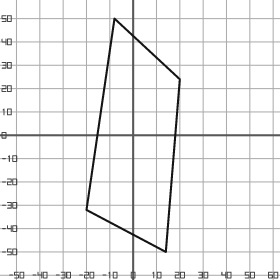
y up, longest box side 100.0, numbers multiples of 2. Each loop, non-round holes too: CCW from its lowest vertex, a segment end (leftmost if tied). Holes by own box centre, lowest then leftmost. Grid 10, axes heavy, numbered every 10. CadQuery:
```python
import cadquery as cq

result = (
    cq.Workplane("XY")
    .moveTo(14.0, -50.0)
    .lineTo(20.0, 24.0)
    .lineTo(-8.0, 50.0)
    .lineTo(-20.0, -32.0)
    .close()
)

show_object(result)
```